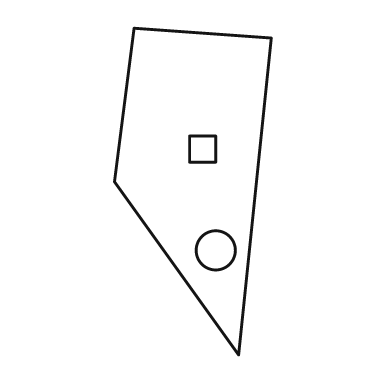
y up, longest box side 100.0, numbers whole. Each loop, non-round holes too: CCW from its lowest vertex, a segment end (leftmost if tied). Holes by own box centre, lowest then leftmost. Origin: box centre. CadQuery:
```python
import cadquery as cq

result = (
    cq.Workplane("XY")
    .moveTo(14.0, -50.0)
    .lineTo(24.0, 47.0)
    .lineTo(-18.0, 50.0)
    .lineTo(-24.0, 3.0)
    .close()
    .moveTo(7.0, -18.0)
    .circle(6.0)
    .moveTo(-1.0, 9.0)
    .lineTo(7.0, 9.0)
    .lineTo(7.0, 17.0)
    .lineTo(-1.0, 17.0)
    .close()
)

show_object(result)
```